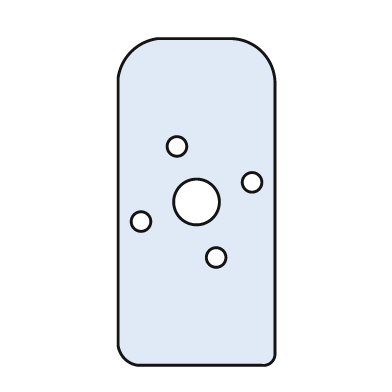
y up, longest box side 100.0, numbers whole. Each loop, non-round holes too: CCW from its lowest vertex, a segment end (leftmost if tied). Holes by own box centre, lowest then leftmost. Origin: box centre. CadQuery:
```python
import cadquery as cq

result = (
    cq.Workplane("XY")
    .moveTo(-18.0, -50.0)
    .lineTo(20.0, -50.0)
    .threePointArc((23.0, -49.0), (24.0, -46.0))
    .lineTo(24.0, 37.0)
    .threePointArc((20.0, 46.0), (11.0, 50.0))
    .lineTo(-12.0, 50.0)
    .threePointArc((-20.0, 46.0), (-24.0, 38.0))
    .lineTo(-24.0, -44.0)
    .threePointArc((-22.0, -48.0), (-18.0, -50.0))
    .close()
    .moveTo(6.0, -17.0)
    .circle(3.0)
    .moveTo(-17.0, -6.0)
    .circle(3.0)
    .moveTo(0.0, 0.0)
    .circle(7.0)
    .moveTo(17.0, 6.0)
    .circle(3.0)
    .moveTo(-6.0, 17.0)
    .circle(3.0)
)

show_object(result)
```